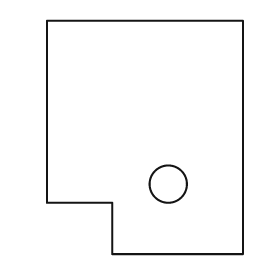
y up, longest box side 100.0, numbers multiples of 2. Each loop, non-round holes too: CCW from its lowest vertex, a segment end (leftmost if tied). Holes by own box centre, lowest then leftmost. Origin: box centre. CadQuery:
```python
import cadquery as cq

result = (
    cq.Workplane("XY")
    .moveTo(-14.0, -50.0)
    .lineTo(42.0, -50.0)
    .lineTo(42.0, 50.0)
    .lineTo(-42.0, 50.0)
    .lineTo(-42.0, -28.0)
    .lineTo(-14.0, -28.0)
    .close()
    .moveTo(10.0, -20.0)
    .circle(8.0)
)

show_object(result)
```